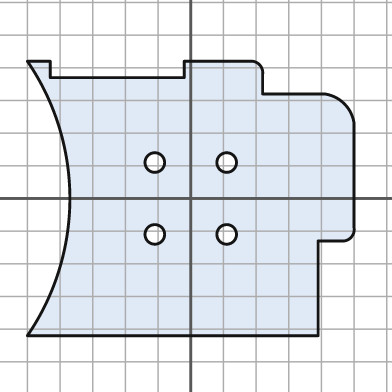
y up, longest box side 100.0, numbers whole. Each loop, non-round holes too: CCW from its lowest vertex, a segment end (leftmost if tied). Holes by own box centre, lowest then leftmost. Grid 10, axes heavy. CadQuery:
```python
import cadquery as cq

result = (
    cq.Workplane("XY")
    .moveTo(-50.0, -42.0)
    .lineTo(39.0, -42.0)
    .lineTo(39.0, -13.0)
    .lineTo(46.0, -13.0)
    .threePointArc((49.0, -12.0), (50.0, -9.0))
    .lineTo(50.0, 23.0)
    .threePointArc((47.0, 29.0), (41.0, 32.0))
    .lineTo(22.0, 32.0)
    .lineTo(22.0, 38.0)
    .threePointArc((21.0, 41.0), (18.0, 42.0))
    .lineTo(-2.0, 42.0)
    .lineTo(-2.0, 37.0)
    .lineTo(-43.0, 37.0)
    .lineTo(-43.0, 42.0)
    .lineTo(-50.0, 42.0)
    .threePointArc((-37.0, 0.0), (-50.0, -42.0))
    .close()
    .moveTo(-11.0, -11.0)
    .circle(3.0)
    .moveTo(11.0, -11.0)
    .circle(3.0)
    .moveTo(-11.0, 11.0)
    .circle(3.0)
    .moveTo(11.0, 11.0)
    .circle(3.0)
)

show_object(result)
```